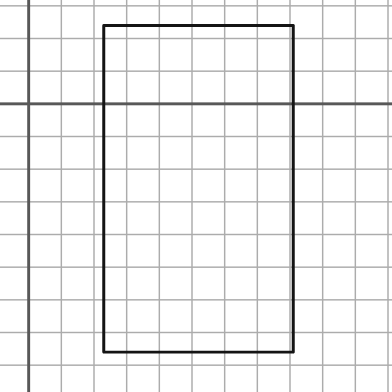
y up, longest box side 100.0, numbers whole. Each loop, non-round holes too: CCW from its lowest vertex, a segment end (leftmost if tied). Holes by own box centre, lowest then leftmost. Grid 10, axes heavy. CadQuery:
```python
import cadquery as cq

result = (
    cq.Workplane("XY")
    .moveTo(23.0, -76.0)
    .lineTo(81.0, -76.0)
    .lineTo(81.0, 24.0)
    .lineTo(23.0, 24.0)
    .close()
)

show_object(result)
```